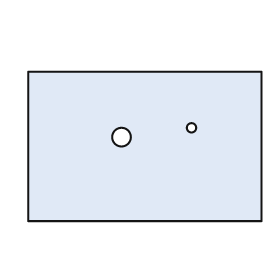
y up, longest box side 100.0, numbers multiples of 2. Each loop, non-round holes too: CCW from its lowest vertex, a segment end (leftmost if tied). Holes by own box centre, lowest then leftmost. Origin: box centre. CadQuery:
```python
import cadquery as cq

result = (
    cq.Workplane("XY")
    .moveTo(-50.0, -32.0)
    .lineTo(50.0, -32.0)
    .lineTo(50.0, 32.0)
    .lineTo(-50.0, 32.0)
    .close()
    .moveTo(-10.0, 4.0)
    .circle(4.0)
    .moveTo(20.0, 8.0)
    .circle(2.0)
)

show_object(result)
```